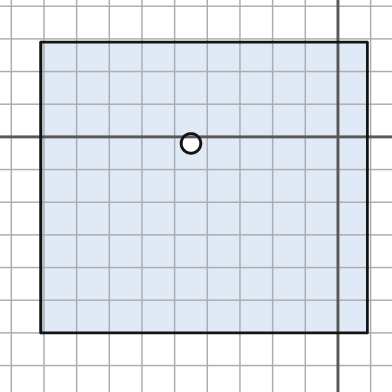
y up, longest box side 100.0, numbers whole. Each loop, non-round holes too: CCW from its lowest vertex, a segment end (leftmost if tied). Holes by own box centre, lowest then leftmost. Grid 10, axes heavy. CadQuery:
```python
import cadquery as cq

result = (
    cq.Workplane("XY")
    .moveTo(-91.0, -60.0)
    .lineTo(9.0, -60.0)
    .lineTo(9.0, 29.0)
    .lineTo(-91.0, 29.0)
    .close()
    .moveTo(-45.0, -2.0)
    .circle(3.0)
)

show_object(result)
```